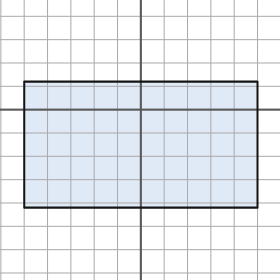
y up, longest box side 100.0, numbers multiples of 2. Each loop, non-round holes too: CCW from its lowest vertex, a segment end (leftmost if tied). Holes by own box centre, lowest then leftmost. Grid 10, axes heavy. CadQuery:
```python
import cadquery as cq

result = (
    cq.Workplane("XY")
    .moveTo(-50.0, -42.0)
    .lineTo(50.0, -42.0)
    .lineTo(50.0, 12.0)
    .lineTo(-50.0, 12.0)
    .close()
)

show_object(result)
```